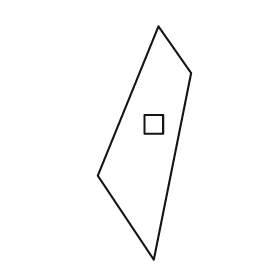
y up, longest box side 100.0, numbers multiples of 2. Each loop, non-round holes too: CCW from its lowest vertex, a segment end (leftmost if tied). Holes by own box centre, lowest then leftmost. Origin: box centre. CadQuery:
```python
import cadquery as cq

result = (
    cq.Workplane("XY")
    .moveTo(4.0, -50.0)
    .lineTo(20.0, 30.0)
    .lineTo(6.0, 50.0)
    .lineTo(-20.0, -14.0)
    .close()
    .moveTo(0.0, 4.0)
    .lineTo(8.0, 4.0)
    .lineTo(8.0, 12.0)
    .lineTo(0.0, 12.0)
    .close()
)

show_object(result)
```